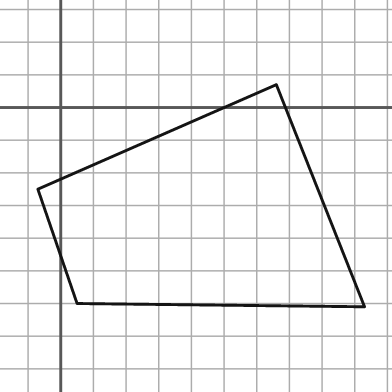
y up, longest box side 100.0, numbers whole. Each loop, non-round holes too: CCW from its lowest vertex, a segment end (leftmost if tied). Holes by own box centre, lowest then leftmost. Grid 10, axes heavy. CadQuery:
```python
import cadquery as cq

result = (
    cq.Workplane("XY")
    .moveTo(93.0, -61.0)
    .lineTo(66.0, 7.0)
    .lineTo(-7.0, -25.0)
    .lineTo(5.0, -60.0)
    .close()
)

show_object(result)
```